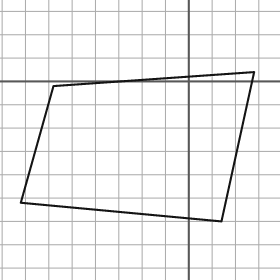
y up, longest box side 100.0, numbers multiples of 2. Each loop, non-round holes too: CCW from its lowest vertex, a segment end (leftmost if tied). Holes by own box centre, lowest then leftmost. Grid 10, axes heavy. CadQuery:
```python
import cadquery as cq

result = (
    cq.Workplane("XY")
    .moveTo(14.0, -60.0)
    .lineTo(28.0, 4.0)
    .lineTo(-58.0, -2.0)
    .lineTo(-72.0, -52.0)
    .close()
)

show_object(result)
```